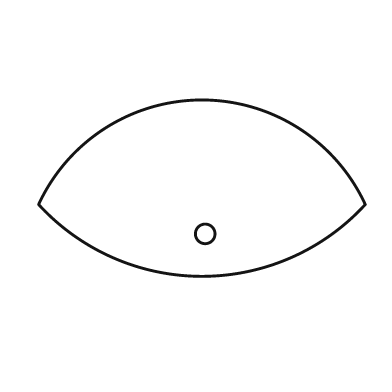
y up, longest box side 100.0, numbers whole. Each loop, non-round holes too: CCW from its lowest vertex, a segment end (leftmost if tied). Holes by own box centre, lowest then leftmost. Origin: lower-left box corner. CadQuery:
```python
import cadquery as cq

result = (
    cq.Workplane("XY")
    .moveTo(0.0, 22.0)
    .threePointArc((50.0, 0.0), (100.0, 22.0))
    .threePointArc((50.0, 54.0), (0.0, 22.0))
    .close()
    .moveTo(51.0, 13.0)
    .circle(3.0)
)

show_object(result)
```